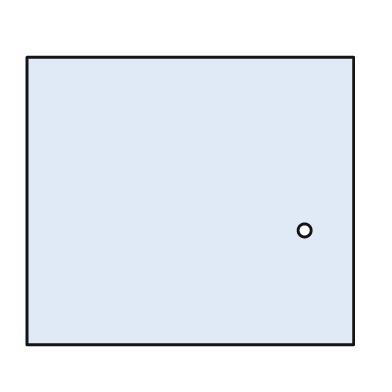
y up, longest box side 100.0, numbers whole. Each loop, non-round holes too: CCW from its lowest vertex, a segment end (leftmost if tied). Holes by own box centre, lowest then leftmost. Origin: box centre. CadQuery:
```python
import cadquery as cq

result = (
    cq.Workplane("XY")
    .moveTo(-50.0, -44.0)
    .lineTo(50.0, -44.0)
    .lineTo(50.0, 44.0)
    .lineTo(-50.0, 44.0)
    .close()
    .moveTo(35.0, -9.0)
    .circle(2.0)
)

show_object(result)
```